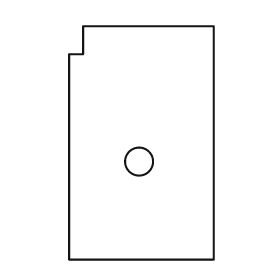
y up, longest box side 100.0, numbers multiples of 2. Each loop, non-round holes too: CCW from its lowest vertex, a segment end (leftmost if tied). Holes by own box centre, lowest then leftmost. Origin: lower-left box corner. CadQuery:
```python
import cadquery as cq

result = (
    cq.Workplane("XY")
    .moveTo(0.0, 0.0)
    .lineTo(62.0, 0.0)
    .lineTo(62.0, 100.0)
    .lineTo(6.0, 100.0)
    .lineTo(6.0, 88.0)
    .lineTo(0.0, 88.0)
    .close()
    .moveTo(30.0, 42.0)
    .circle(6.0)
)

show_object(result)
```